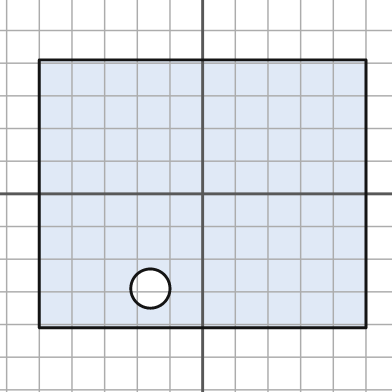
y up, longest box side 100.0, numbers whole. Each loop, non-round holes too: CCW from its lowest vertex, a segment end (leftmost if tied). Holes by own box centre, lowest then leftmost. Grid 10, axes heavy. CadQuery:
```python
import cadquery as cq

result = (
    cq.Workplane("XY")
    .moveTo(-50.0, -41.0)
    .lineTo(50.0, -41.0)
    .lineTo(50.0, 41.0)
    .lineTo(-50.0, 41.0)
    .close()
    .moveTo(-16.0, -29.0)
    .circle(6.0)
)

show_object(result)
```